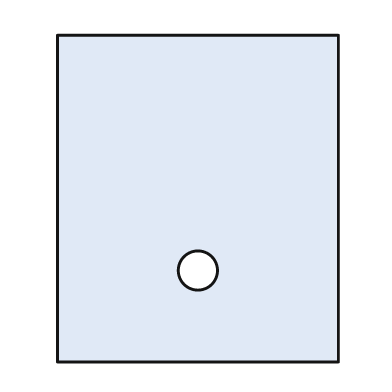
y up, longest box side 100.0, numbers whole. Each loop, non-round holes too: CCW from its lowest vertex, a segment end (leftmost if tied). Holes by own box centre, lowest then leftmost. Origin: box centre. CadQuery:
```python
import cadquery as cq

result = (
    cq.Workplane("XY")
    .moveTo(-43.0, -50.0)
    .lineTo(43.0, -50.0)
    .lineTo(43.0, 50.0)
    .lineTo(-43.0, 50.0)
    .close()
    .moveTo(0.0, -22.0)
    .circle(6.0)
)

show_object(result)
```